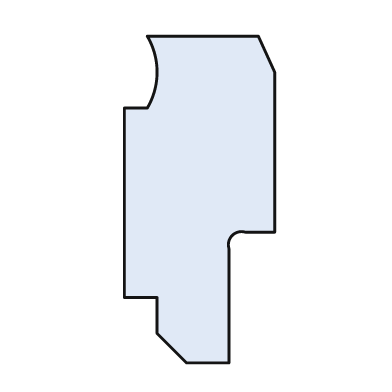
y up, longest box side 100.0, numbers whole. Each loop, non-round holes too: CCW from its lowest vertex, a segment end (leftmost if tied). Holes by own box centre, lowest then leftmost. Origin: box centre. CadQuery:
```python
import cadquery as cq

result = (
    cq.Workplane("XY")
    .moveTo(-4.0, -50.0)
    .lineTo(9.0, -50.0)
    .lineTo(9.0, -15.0)
    .threePointArc((10.0, -11.0), (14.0, -10.0))
    .lineTo(23.0, -10.0)
    .lineTo(23.0, 39.0)
    .lineTo(18.0, 50.0)
    .lineTo(-16.0, 50.0)
    .threePointArc((-13.0, 39.0), (-16.0, 28.0))
    .lineTo(-23.0, 28.0)
    .lineTo(-23.0, -30.0)
    .lineTo(-13.0, -30.0)
    .lineTo(-13.0, -41.0)
    .close()
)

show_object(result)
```